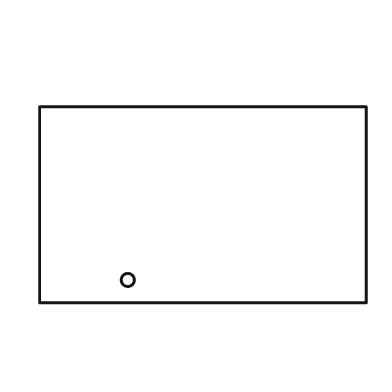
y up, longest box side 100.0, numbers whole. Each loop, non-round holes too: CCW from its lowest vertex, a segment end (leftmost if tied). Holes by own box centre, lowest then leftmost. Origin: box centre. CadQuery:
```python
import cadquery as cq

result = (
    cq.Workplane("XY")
    .moveTo(-50.0, -30.0)
    .lineTo(50.0, -30.0)
    .lineTo(50.0, 30.0)
    .lineTo(-50.0, 30.0)
    .close()
    .moveTo(-23.0, -23.0)
    .circle(2.0)
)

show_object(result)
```